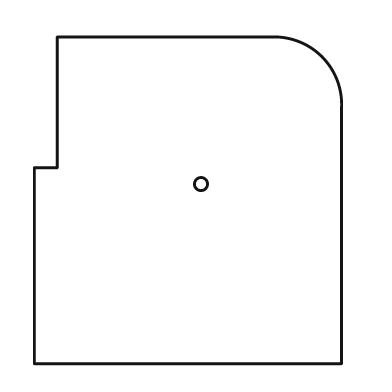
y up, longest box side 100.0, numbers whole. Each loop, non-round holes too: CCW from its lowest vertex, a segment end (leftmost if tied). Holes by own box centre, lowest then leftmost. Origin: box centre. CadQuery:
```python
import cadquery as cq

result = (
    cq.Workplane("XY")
    .moveTo(-47.0, -50.0)
    .lineTo(47.0, -50.0)
    .lineTo(47.0, 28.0)
    .threePointArc((41.0, 44.0), (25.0, 50.0))
    .lineTo(-40.0, 50.0)
    .lineTo(-40.0, 10.0)
    .lineTo(-47.0, 10.0)
    .close()
    .moveTo(4.0, 5.0)
    .circle(2.0)
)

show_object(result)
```